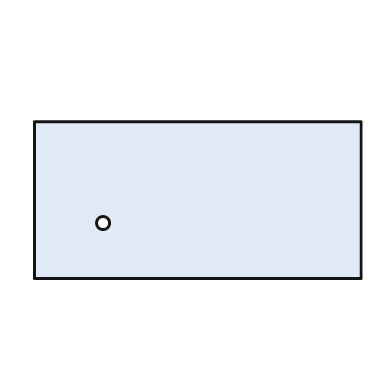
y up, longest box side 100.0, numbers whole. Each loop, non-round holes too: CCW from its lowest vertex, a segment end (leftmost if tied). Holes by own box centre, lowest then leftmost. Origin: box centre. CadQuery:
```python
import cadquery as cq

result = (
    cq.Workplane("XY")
    .moveTo(-50.0, -24.0)
    .lineTo(50.0, -24.0)
    .lineTo(50.0, 24.0)
    .lineTo(-50.0, 24.0)
    .close()
    .moveTo(-29.0, -7.0)
    .circle(2.0)
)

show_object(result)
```